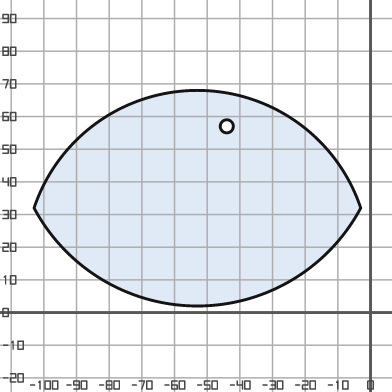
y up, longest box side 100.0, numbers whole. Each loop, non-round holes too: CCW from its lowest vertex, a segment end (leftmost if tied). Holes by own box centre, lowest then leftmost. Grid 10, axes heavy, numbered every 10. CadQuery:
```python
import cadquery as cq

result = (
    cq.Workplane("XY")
    .moveTo(-103.0, 32.0)
    .threePointArc((-53.0, 2.0), (-3.0, 32.0))
    .threePointArc((-53.0, 68.0), (-103.0, 32.0))
    .close()
    .moveTo(-44.0, 57.0)
    .circle(2.0)
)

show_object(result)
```